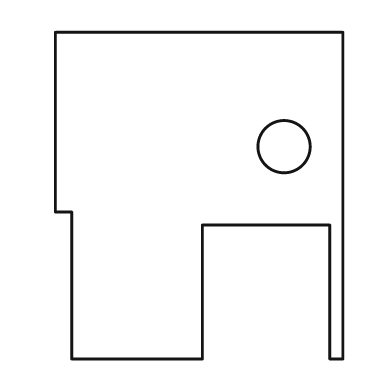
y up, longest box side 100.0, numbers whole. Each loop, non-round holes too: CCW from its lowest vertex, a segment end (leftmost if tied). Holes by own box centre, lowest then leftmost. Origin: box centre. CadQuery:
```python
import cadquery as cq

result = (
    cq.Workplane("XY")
    .moveTo(-39.0, -50.0)
    .lineTo(1.0, -50.0)
    .lineTo(1.0, -9.0)
    .lineTo(40.0, -9.0)
    .lineTo(40.0, -50.0)
    .lineTo(44.0, -50.0)
    .lineTo(44.0, 50.0)
    .lineTo(-44.0, 50.0)
    .lineTo(-44.0, -5.0)
    .lineTo(-39.0, -5.0)
    .close()
    .moveTo(26.0, 15.0)
    .circle(8.0)
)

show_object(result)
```